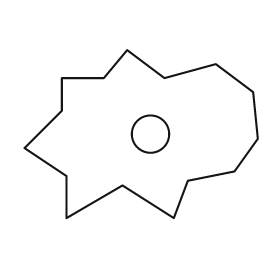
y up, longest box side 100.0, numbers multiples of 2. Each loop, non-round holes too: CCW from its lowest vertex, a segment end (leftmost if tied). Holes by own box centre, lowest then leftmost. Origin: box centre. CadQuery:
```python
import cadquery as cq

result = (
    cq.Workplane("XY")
    .moveTo(-32.0, -36.0)
    .lineTo(-8.0, -22.0)
    .lineTo(14.0, -36.0)
    .lineTo(20.0, -20.0)
    .lineTo(40.0, -16.0)
    .lineTo(50.0, -2.0)
    .lineTo(48.0, 18.0)
    .lineTo(32.0, 30.0)
    .lineTo(10.0, 24.0)
    .lineTo(-6.0, 36.0)
    .lineTo(-16.0, 24.0)
    .lineTo(-34.0, 24.0)
    .lineTo(-34.0, 10.0)
    .lineTo(-50.0, -6.0)
    .lineTo(-32.0, -18.0)
    .close()
    .moveTo(4.0, 0.0)
    .circle(8.0)
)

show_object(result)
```